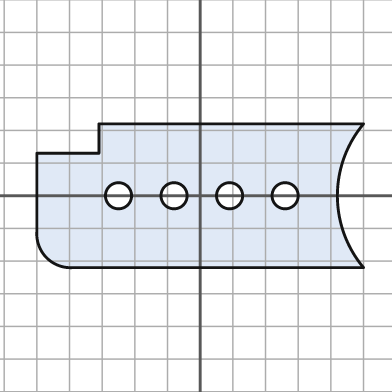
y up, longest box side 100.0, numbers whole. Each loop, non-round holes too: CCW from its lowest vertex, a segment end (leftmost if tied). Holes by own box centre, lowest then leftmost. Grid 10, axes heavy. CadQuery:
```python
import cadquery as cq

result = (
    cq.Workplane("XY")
    .moveTo(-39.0, -22.0)
    .lineTo(50.0, -22.0)
    .threePointArc((42.0, 0.0), (50.0, 22.0))
    .lineTo(-31.0, 22.0)
    .lineTo(-31.0, 13.0)
    .lineTo(-50.0, 13.0)
    .lineTo(-50.0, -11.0)
    .threePointArc((-47.0, -19.0), (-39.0, -22.0))
    .close()
    .moveTo(-25.0, 0.0)
    .circle(4.0)
    .moveTo(-8.0, 0.0)
    .circle(4.0)
    .moveTo(9.0, 0.0)
    .circle(4.0)
    .moveTo(26.0, 0.0)
    .circle(4.0)
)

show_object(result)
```